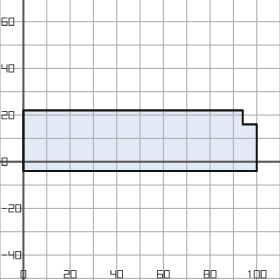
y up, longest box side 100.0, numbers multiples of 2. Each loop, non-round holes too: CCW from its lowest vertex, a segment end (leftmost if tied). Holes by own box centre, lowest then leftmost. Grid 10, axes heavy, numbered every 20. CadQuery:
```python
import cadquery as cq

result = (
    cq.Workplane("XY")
    .moveTo(0.0, -4.0)
    .lineTo(100.0, -4.0)
    .lineTo(100.0, 16.0)
    .lineTo(94.0, 16.0)
    .lineTo(94.0, 22.0)
    .lineTo(0.0, 22.0)
    .close()
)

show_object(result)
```